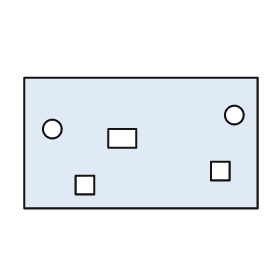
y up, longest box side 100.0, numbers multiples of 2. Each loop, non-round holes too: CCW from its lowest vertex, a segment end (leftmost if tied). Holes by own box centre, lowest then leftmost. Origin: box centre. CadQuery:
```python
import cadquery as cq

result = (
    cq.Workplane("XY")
    .moveTo(-50.0, -28.0)
    .lineTo(50.0, -28.0)
    .lineTo(50.0, 28.0)
    .lineTo(-50.0, 28.0)
    .close()
    .moveTo(-28.0, -22.0)
    .lineTo(-20.0, -22.0)
    .lineTo(-20.0, -14.0)
    .lineTo(-28.0, -14.0)
    .close()
    .moveTo(30.0, -16.0)
    .lineTo(38.0, -16.0)
    .lineTo(38.0, -8.0)
    .lineTo(30.0, -8.0)
    .close()
    .moveTo(-14.0, -2.0)
    .lineTo(-2.0, -2.0)
    .lineTo(-2.0, 6.0)
    .lineTo(-14.0, 6.0)
    .close()
    .moveTo(-38.0, 6.0)
    .circle(4.0)
    .moveTo(40.0, 12.0)
    .circle(4.0)
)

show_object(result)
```